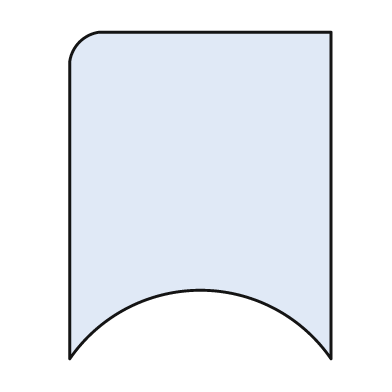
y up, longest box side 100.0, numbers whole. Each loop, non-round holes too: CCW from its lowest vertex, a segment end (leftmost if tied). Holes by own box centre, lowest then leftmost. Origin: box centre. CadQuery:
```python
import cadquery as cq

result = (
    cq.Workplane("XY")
    .moveTo(-40.0, -50.0)
    .threePointArc((0.0, -29.0), (40.0, -50.0))
    .lineTo(40.0, 50.0)
    .lineTo(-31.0, 50.0)
    .threePointArc((-37.0, 47.0), (-40.0, 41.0))
    .close()
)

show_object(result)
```